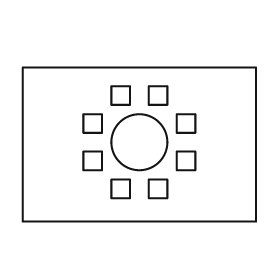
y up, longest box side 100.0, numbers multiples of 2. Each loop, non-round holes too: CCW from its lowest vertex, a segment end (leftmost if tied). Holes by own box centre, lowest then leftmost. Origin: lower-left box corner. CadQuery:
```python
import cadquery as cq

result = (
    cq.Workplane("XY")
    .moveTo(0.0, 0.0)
    .lineTo(100.0, 0.0)
    .lineTo(100.0, 66.0)
    .lineTo(0.0, 66.0)
    .close()
    .moveTo(38.0, 10.0)
    .lineTo(46.0, 10.0)
    .lineTo(46.0, 18.0)
    .lineTo(38.0, 18.0)
    .close()
    .moveTo(54.0, 10.0)
    .lineTo(62.0, 10.0)
    .lineTo(62.0, 18.0)
    .lineTo(54.0, 18.0)
    .close()
    .moveTo(26.0, 22.0)
    .lineTo(34.0, 22.0)
    .lineTo(34.0, 30.0)
    .lineTo(26.0, 30.0)
    .close()
    .moveTo(66.0, 22.0)
    .lineTo(74.0, 22.0)
    .lineTo(74.0, 30.0)
    .lineTo(66.0, 30.0)
    .close()
    .moveTo(50.0, 34.0)
    .circle(12.0)
    .moveTo(26.0, 38.0)
    .lineTo(34.0, 38.0)
    .lineTo(34.0, 46.0)
    .lineTo(26.0, 46.0)
    .close()
    .moveTo(66.0, 38.0)
    .lineTo(74.0, 38.0)
    .lineTo(74.0, 46.0)
    .lineTo(66.0, 46.0)
    .close()
    .moveTo(38.0, 50.0)
    .lineTo(46.0, 50.0)
    .lineTo(46.0, 58.0)
    .lineTo(38.0, 58.0)
    .close()
    .moveTo(54.0, 50.0)
    .lineTo(62.0, 50.0)
    .lineTo(62.0, 58.0)
    .lineTo(54.0, 58.0)
    .close()
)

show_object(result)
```